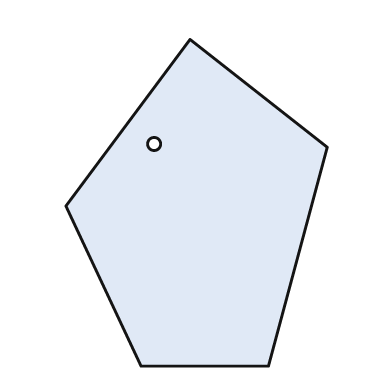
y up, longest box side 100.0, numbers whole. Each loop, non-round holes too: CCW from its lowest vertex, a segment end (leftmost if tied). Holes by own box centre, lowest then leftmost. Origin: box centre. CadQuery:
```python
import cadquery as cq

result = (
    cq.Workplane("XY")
    .moveTo(-17.0, -50.0)
    .lineTo(22.0, -50.0)
    .lineTo(40.0, 17.0)
    .lineTo(-2.0, 50.0)
    .lineTo(-40.0, -1.0)
    .close()
    .moveTo(-13.0, 18.0)
    .circle(2.0)
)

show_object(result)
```